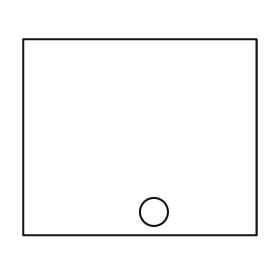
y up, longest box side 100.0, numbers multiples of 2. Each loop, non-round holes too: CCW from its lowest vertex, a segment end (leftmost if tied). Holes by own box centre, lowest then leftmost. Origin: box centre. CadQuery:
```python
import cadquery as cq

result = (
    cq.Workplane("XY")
    .moveTo(-50.0, -42.0)
    .lineTo(50.0, -42.0)
    .lineTo(50.0, 42.0)
    .lineTo(-50.0, 42.0)
    .close()
    .moveTo(6.0, -32.0)
    .circle(6.0)
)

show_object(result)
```